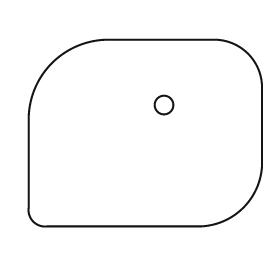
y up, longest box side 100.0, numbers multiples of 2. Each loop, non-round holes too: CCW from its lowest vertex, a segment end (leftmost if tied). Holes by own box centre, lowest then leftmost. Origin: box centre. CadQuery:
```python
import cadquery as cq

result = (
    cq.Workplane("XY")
    .moveTo(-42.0, -40.0)
    .lineTo(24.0, -40.0)
    .threePointArc((42.0, -32.0), (50.0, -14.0))
    .lineTo(50.0, 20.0)
    .threePointArc((44.0, 34.0), (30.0, 40.0))
    .lineTo(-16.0, 40.0)
    .threePointArc((-40.0, 30.0), (-50.0, 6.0))
    .lineTo(-50.0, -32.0)
    .threePointArc((-48.0, -38.0), (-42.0, -40.0))
    .close()
    .moveTo(8.0, 12.0)
    .circle(4.0)
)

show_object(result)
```